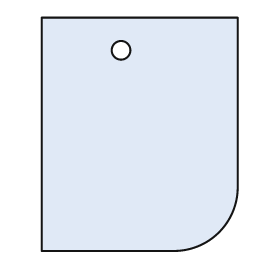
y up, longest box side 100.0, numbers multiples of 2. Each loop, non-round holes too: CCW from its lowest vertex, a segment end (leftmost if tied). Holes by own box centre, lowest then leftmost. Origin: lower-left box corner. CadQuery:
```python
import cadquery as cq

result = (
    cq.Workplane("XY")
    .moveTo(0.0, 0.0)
    .lineTo(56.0, 0.0)
    .threePointArc((76.0, 8.0), (84.0, 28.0))
    .lineTo(84.0, 100.0)
    .lineTo(0.0, 100.0)
    .close()
    .moveTo(34.0, 86.0)
    .circle(4.0)
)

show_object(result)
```